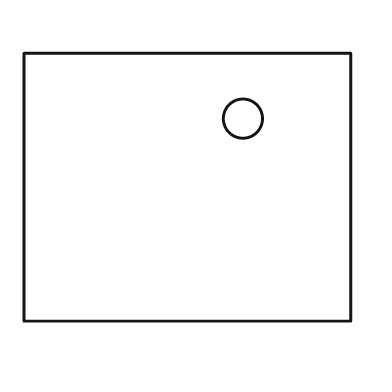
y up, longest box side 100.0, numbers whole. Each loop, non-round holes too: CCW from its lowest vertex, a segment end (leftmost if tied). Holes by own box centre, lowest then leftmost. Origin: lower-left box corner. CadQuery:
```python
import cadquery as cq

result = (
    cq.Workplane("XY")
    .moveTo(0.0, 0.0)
    .lineTo(100.0, 0.0)
    .lineTo(100.0, 82.0)
    .lineTo(0.0, 82.0)
    .close()
    .moveTo(67.0, 62.0)
    .circle(6.0)
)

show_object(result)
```